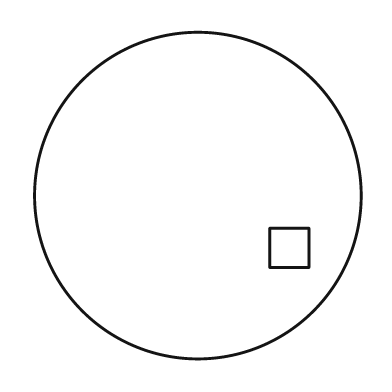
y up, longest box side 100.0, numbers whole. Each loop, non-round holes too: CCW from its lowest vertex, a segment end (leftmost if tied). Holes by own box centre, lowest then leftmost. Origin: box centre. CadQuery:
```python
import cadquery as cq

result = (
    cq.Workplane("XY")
    .moveTo(0.0, 0.0)
    .circle(50.0)
    .moveTo(22.0, -22.0)
    .lineTo(34.0, -22.0)
    .lineTo(34.0, -10.0)
    .lineTo(22.0, -10.0)
    .close()
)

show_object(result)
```